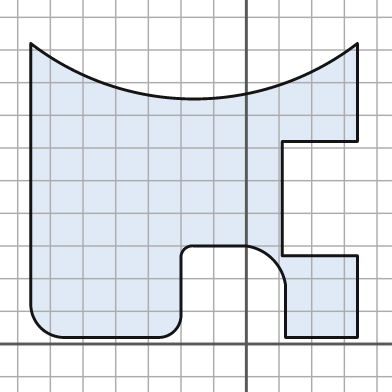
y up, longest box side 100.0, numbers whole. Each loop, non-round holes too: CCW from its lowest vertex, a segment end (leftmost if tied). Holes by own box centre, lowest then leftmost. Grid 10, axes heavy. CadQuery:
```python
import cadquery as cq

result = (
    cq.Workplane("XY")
    .moveTo(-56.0, 2.0)
    .lineTo(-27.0, 2.0)
    .threePointArc((-22.0, 4.0), (-20.0, 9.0))
    .lineTo(-20.0, 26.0)
    .threePointArc((-19.0, 29.0), (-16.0, 30.0))
    .lineTo(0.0, 30.0)
    .threePointArc((8.0, 26.0), (12.0, 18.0))
    .lineTo(12.0, 2.0)
    .lineTo(34.0, 2.0)
    .lineTo(34.0, 27.0)
    .lineTo(11.0, 27.0)
    .lineTo(11.0, 62.0)
    .lineTo(34.0, 62.0)
    .lineTo(34.0, 92.0)
    .threePointArc((-16.0, 75.0), (-66.0, 92.0))
    .lineTo(-66.0, 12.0)
    .threePointArc((-63.0, 5.0), (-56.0, 2.0))
    .close()
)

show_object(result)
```